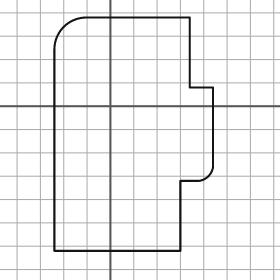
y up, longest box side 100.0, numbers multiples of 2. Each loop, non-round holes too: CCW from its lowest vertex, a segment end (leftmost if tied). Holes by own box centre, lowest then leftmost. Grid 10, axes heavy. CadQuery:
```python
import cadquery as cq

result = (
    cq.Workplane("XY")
    .moveTo(-24.0, -62.0)
    .lineTo(30.0, -62.0)
    .lineTo(30.0, -32.0)
    .lineTo(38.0, -32.0)
    .threePointArc((42.0, -30.0), (44.0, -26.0))
    .lineTo(44.0, 8.0)
    .lineTo(34.0, 8.0)
    .lineTo(34.0, 38.0)
    .lineTo(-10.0, 38.0)
    .threePointArc((-20.0, 34.0), (-24.0, 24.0))
    .close()
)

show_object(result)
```